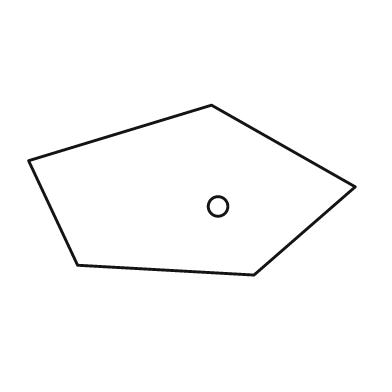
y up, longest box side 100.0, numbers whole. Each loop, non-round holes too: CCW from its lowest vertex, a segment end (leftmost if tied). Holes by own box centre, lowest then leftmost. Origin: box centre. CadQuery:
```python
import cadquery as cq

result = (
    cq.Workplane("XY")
    .moveTo(19.0, -26.0)
    .lineTo(50.0, 1.0)
    .lineTo(6.0, 26.0)
    .lineTo(-50.0, 9.0)
    .lineTo(-35.0, -23.0)
    .close()
    .moveTo(8.0, -5.0)
    .circle(3.0)
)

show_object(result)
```